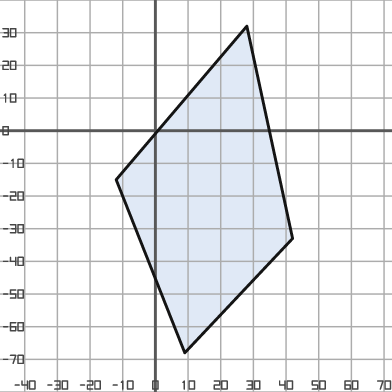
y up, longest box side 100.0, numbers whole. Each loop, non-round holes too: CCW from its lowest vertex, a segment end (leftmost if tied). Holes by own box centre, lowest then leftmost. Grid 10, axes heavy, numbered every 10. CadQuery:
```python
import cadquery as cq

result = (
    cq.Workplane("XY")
    .moveTo(9.0, -68.0)
    .lineTo(42.0, -33.0)
    .lineTo(28.0, 32.0)
    .lineTo(-12.0, -15.0)
    .close()
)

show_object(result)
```